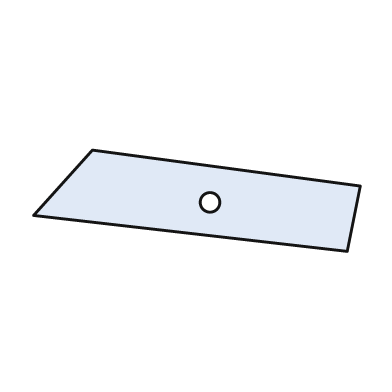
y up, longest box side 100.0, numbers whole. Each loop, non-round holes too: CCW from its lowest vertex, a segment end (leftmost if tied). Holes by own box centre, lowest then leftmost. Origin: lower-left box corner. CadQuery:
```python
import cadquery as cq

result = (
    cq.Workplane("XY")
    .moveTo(96.0, 0.0)
    .lineTo(100.0, 20.0)
    .lineTo(18.0, 31.0)
    .lineTo(0.0, 11.0)
    .close()
    .moveTo(54.0, 15.0)
    .circle(3.0)
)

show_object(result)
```